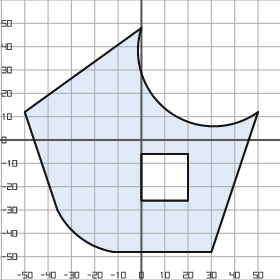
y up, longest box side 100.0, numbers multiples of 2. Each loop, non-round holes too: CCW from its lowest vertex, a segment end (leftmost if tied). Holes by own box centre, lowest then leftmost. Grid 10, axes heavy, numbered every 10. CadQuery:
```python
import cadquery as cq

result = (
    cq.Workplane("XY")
    .moveTo(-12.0, -48.0)
    .lineTo(30.0, -48.0)
    .lineTo(50.0, 12.0)
    .threePointArc((12.0, 12.0), (0.0, 48.0))
    .lineTo(-50.0, 12.0)
    .lineTo(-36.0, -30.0)
    .threePointArc((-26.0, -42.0), (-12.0, -48.0))
    .close()
    .moveTo(0.0, -26.0)
    .lineTo(20.0, -26.0)
    .lineTo(20.0, -6.0)
    .lineTo(0.0, -6.0)
    .close()
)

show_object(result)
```